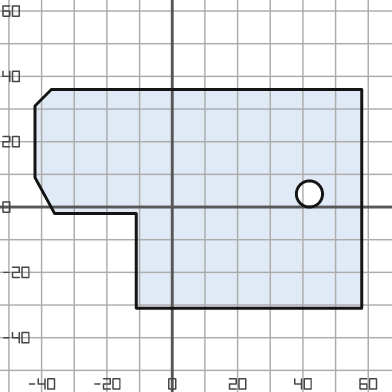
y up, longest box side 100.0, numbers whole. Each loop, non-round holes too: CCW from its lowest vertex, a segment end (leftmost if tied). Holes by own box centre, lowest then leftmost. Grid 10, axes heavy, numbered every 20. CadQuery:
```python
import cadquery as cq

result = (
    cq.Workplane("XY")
    .moveTo(-11.0, -31.0)
    .lineTo(58.0, -31.0)
    .lineTo(58.0, 36.0)
    .lineTo(-37.0, 36.0)
    .lineTo(-42.0, 31.0)
    .lineTo(-42.0, 9.0)
    .lineTo(-36.0, -2.0)
    .lineTo(-11.0, -2.0)
    .close()
    .moveTo(42.0, 4.0)
    .circle(4.0)
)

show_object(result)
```